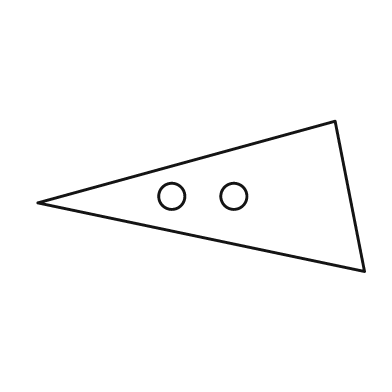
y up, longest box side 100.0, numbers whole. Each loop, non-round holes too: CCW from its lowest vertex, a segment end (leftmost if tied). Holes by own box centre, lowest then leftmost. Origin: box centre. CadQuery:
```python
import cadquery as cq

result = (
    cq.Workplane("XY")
    .moveTo(50.0, -23.0)
    .lineTo(41.0, 23.0)
    .lineTo(-50.0, -2.0)
    .close()
    .moveTo(-9.0, 0.0)
    .circle(4.0)
    .moveTo(10.0, 0.0)
    .circle(4.0)
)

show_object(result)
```